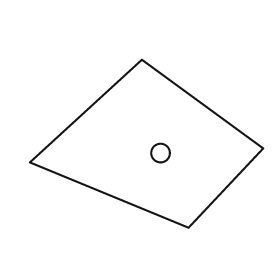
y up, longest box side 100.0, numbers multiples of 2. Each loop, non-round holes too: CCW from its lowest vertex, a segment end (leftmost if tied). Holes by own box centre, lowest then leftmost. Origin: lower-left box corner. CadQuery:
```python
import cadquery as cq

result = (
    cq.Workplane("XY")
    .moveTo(68.0, 0.0)
    .lineTo(100.0, 34.0)
    .lineTo(48.0, 72.0)
    .lineTo(0.0, 28.0)
    .close()
    .moveTo(56.0, 32.0)
    .circle(4.0)
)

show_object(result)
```